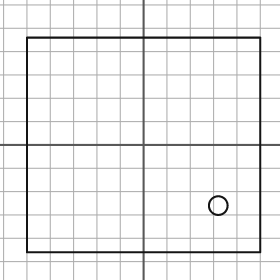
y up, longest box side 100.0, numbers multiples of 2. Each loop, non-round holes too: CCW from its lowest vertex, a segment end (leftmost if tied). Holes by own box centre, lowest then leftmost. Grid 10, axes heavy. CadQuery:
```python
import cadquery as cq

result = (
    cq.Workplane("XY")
    .moveTo(-50.0, -46.0)
    .lineTo(50.0, -46.0)
    .lineTo(50.0, 46.0)
    .lineTo(-50.0, 46.0)
    .close()
    .moveTo(32.0, -26.0)
    .circle(4.0)
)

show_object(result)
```